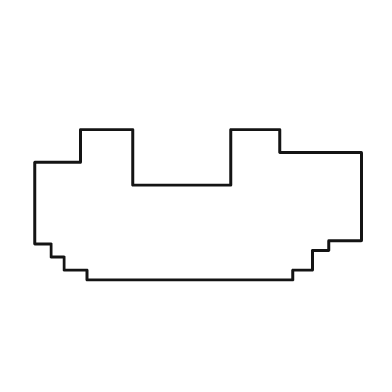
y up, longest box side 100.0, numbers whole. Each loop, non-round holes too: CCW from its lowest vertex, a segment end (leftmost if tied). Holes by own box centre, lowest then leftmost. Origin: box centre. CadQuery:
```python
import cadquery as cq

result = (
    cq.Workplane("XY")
    .moveTo(-34.0, -23.0)
    .lineTo(29.0, -23.0)
    .lineTo(29.0, -20.0)
    .lineTo(35.0, -20.0)
    .lineTo(35.0, -14.0)
    .lineTo(40.0, -14.0)
    .lineTo(40.0, -11.0)
    .lineTo(50.0, -11.0)
    .lineTo(50.0, 16.0)
    .lineTo(25.0, 16.0)
    .lineTo(25.0, 23.0)
    .lineTo(10.0, 23.0)
    .lineTo(10.0, 6.0)
    .lineTo(-20.0, 6.0)
    .lineTo(-20.0, 23.0)
    .lineTo(-36.0, 23.0)
    .lineTo(-36.0, 13.0)
    .lineTo(-50.0, 13.0)
    .lineTo(-50.0, -12.0)
    .lineTo(-45.0, -12.0)
    .lineTo(-45.0, -16.0)
    .lineTo(-41.0, -16.0)
    .lineTo(-41.0, -20.0)
    .lineTo(-34.0, -20.0)
    .close()
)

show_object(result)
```